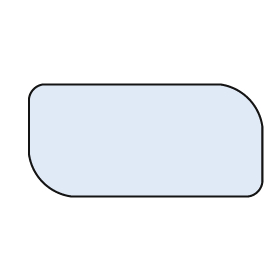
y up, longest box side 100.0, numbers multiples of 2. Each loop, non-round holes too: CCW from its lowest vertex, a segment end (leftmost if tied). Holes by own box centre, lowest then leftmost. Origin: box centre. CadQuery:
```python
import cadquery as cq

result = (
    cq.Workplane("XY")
    .moveTo(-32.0, -24.0)
    .lineTo(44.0, -24.0)
    .threePointArc((48.0, -22.0), (50.0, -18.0))
    .lineTo(50.0, 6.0)
    .threePointArc((44.0, 18.0), (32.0, 24.0))
    .lineTo(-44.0, 24.0)
    .threePointArc((-48.0, 22.0), (-50.0, 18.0))
    .lineTo(-50.0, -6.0)
    .threePointArc((-44.0, -18.0), (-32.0, -24.0))
    .close()
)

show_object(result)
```